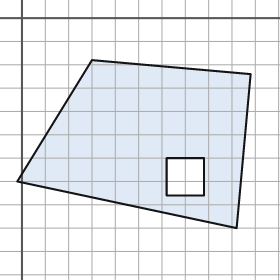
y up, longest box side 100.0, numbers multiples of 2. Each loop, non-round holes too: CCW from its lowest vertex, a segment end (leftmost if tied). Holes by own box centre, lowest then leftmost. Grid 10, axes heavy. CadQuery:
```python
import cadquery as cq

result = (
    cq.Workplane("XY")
    .moveTo(92.0, -90.0)
    .lineTo(98.0, -24.0)
    .lineTo(30.0, -18.0)
    .lineTo(-2.0, -70.0)
    .close()
    .moveTo(62.0, -76.0)
    .lineTo(78.0, -76.0)
    .lineTo(78.0, -60.0)
    .lineTo(62.0, -60.0)
    .close()
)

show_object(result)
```